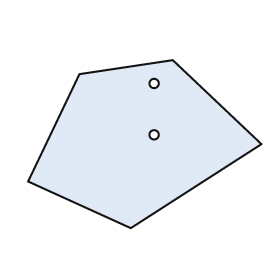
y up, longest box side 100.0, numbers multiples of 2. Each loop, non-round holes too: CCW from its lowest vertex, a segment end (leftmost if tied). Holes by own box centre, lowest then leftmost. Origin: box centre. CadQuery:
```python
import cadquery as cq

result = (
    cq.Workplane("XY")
    .moveTo(-6.0, -36.0)
    .lineTo(50.0, 0.0)
    .lineTo(12.0, 36.0)
    .lineTo(-28.0, 30.0)
    .lineTo(-50.0, -16.0)
    .close()
    .moveTo(4.0, 4.0)
    .circle(2.0)
    .moveTo(4.0, 26.0)
    .circle(2.0)
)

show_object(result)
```